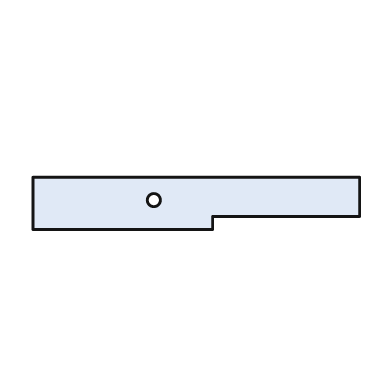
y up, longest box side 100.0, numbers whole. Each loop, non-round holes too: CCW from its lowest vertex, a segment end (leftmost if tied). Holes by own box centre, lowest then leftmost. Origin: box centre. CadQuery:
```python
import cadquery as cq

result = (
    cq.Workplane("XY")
    .moveTo(-50.0, -8.0)
    .lineTo(5.0, -8.0)
    .lineTo(5.0, -4.0)
    .lineTo(50.0, -4.0)
    .lineTo(50.0, 8.0)
    .lineTo(-50.0, 8.0)
    .close()
    .moveTo(-13.0, 1.0)
    .circle(2.0)
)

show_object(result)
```